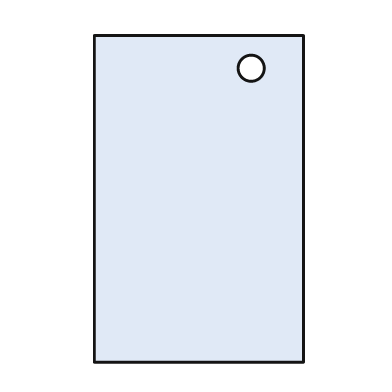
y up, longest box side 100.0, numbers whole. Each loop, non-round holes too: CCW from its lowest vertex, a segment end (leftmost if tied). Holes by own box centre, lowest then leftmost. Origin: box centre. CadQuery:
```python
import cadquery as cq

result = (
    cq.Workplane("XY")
    .moveTo(-32.0, -50.0)
    .lineTo(32.0, -50.0)
    .lineTo(32.0, 50.0)
    .lineTo(-32.0, 50.0)
    .close()
    .moveTo(16.0, 40.0)
    .circle(4.0)
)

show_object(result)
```